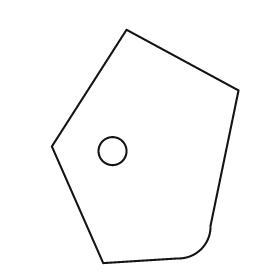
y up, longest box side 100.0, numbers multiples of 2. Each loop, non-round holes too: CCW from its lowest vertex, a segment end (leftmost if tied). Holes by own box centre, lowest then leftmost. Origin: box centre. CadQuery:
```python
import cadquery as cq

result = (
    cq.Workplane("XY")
    .moveTo(-18.0, -50.0)
    .lineTo(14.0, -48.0)
    .threePointArc((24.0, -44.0), (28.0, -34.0))
    .lineTo(40.0, 24.0)
    .lineTo(-8.0, 50.0)
    .lineTo(-40.0, 0.0)
    .close()
    .moveTo(-14.0, -2.0)
    .circle(6.0)
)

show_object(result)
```